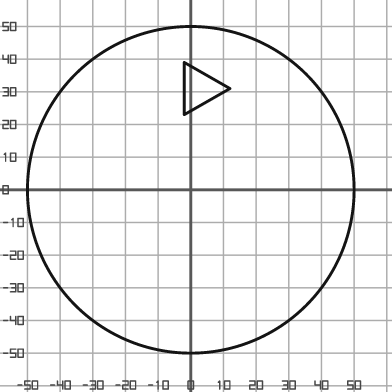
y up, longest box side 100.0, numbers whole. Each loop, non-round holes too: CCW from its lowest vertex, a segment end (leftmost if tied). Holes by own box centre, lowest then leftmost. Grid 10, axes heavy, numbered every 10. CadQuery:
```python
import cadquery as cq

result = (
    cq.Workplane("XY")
    .moveTo(0.0, 0.0)
    .circle(50.0)
    .moveTo(-2.0, 23.0)
    .lineTo(12.0, 31.0)
    .lineTo(-2.0, 39.0)
    .close()
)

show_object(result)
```